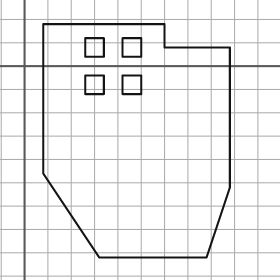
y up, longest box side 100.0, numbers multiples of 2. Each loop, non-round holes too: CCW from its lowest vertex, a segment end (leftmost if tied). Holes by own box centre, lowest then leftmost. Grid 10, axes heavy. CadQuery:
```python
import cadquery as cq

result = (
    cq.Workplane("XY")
    .moveTo(32.0, -82.0)
    .lineTo(78.0, -82.0)
    .lineTo(88.0, -52.0)
    .lineTo(88.0, 8.0)
    .lineTo(60.0, 8.0)
    .lineTo(60.0, 18.0)
    .lineTo(8.0, 18.0)
    .lineTo(8.0, -46.0)
    .close()
    .moveTo(26.0, -12.0)
    .lineTo(34.0, -12.0)
    .lineTo(34.0, -4.0)
    .lineTo(26.0, -4.0)
    .close()
    .moveTo(42.0, -12.0)
    .lineTo(50.0, -12.0)
    .lineTo(50.0, -4.0)
    .lineTo(42.0, -4.0)
    .close()
    .moveTo(26.0, 4.0)
    .lineTo(34.0, 4.0)
    .lineTo(34.0, 12.0)
    .lineTo(26.0, 12.0)
    .close()
    .moveTo(42.0, 4.0)
    .lineTo(50.0, 4.0)
    .lineTo(50.0, 12.0)
    .lineTo(42.0, 12.0)
    .close()
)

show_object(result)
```